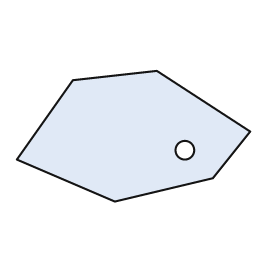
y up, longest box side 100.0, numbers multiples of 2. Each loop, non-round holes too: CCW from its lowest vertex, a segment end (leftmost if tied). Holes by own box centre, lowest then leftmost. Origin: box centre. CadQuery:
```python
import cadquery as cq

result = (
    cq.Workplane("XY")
    .moveTo(-8.0, -28.0)
    .lineTo(34.0, -18.0)
    .lineTo(50.0, 2.0)
    .lineTo(10.0, 28.0)
    .lineTo(-26.0, 24.0)
    .lineTo(-50.0, -10.0)
    .close()
    .moveTo(22.0, -6.0)
    .circle(4.0)
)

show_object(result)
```